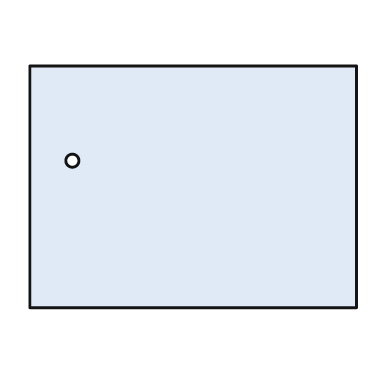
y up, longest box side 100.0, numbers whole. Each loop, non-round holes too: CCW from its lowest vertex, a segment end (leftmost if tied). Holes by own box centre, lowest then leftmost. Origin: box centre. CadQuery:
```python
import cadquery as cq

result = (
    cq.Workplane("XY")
    .moveTo(-50.0, -37.0)
    .lineTo(50.0, -37.0)
    .lineTo(50.0, 37.0)
    .lineTo(-50.0, 37.0)
    .close()
    .moveTo(-37.0, 8.0)
    .circle(2.0)
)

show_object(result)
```